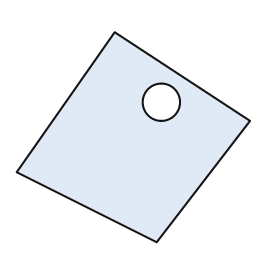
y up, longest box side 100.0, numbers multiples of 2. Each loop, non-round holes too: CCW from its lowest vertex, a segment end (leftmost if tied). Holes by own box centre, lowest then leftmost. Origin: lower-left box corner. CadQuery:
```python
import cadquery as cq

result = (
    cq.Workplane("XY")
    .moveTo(60.0, 0.0)
    .lineTo(100.0, 52.0)
    .lineTo(42.0, 90.0)
    .lineTo(0.0, 30.0)
    .close()
    .moveTo(62.0, 60.0)
    .circle(8.0)
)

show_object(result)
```